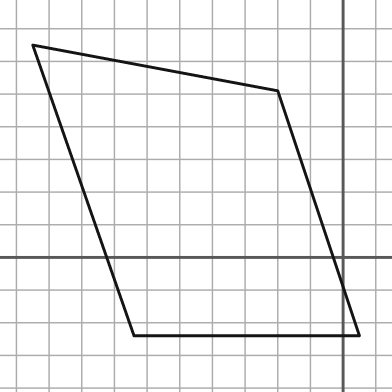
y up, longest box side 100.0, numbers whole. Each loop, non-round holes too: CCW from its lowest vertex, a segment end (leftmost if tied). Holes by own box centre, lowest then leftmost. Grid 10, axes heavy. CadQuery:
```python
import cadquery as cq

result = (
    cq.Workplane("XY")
    .moveTo(-64.0, -24.0)
    .lineTo(5.0, -24.0)
    .lineTo(-20.0, 51.0)
    .lineTo(-95.0, 65.0)
    .close()
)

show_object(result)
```